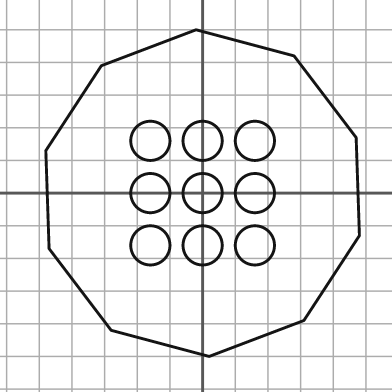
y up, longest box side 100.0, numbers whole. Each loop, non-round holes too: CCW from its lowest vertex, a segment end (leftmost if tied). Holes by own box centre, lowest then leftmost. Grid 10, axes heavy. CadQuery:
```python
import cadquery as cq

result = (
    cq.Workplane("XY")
    .moveTo(2.0, -50.0)
    .lineTo(31.0, -39.0)
    .lineTo(48.0, -13.0)
    .lineTo(47.0, 17.0)
    .lineTo(28.0, 42.0)
    .lineTo(-2.0, 50.0)
    .lineTo(-31.0, 39.0)
    .lineTo(-48.0, 13.0)
    .lineTo(-47.0, -17.0)
    .lineTo(-28.0, -42.0)
    .close()
    .moveTo(-16.0, -16.0)
    .circle(6.0)
    .moveTo(0.0, -16.0)
    .circle(6.0)
    .moveTo(16.0, -16.0)
    .circle(6.0)
    .moveTo(-16.0, 0.0)
    .circle(6.0)
    .moveTo(0.0, 0.0)
    .circle(6.0)
    .moveTo(16.0, 0.0)
    .circle(6.0)
    .moveTo(-16.0, 16.0)
    .circle(6.0)
    .moveTo(0.0, 16.0)
    .circle(6.0)
    .moveTo(16.0, 16.0)
    .circle(6.0)
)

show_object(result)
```